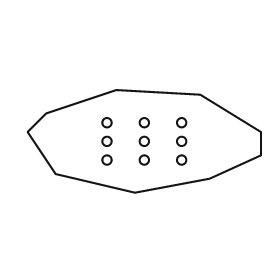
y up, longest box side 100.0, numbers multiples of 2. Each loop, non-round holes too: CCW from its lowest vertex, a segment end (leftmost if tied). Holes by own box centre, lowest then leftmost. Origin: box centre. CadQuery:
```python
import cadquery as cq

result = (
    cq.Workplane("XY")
    .moveTo(-4.0, -22.0)
    .lineTo(28.0, -16.0)
    .lineTo(50.0, -6.0)
    .lineTo(50.0, 4.0)
    .lineTo(24.0, 20.0)
    .lineTo(-12.0, 22.0)
    .lineTo(-42.0, 12.0)
    .lineTo(-50.0, 4.0)
    .lineTo(-38.0, -14.0)
    .close()
    .moveTo(-16.0, -8.0)
    .circle(2.0)
    .moveTo(0.0, -8.0)
    .circle(2.0)
    .moveTo(16.0, -8.0)
    .circle(2.0)
    .moveTo(-16.0, 0.0)
    .circle(2.0)
    .moveTo(0.0, 0.0)
    .circle(2.0)
    .moveTo(16.0, 0.0)
    .circle(2.0)
    .moveTo(-16.0, 8.0)
    .circle(2.0)
    .moveTo(0.0, 8.0)
    .circle(2.0)
    .moveTo(16.0, 8.0)
    .circle(2.0)
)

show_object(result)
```